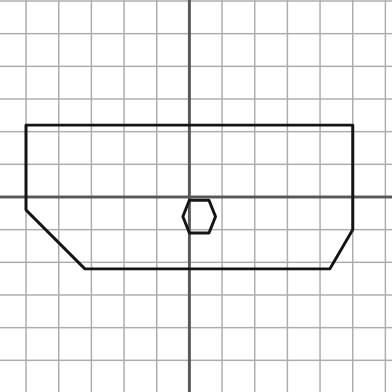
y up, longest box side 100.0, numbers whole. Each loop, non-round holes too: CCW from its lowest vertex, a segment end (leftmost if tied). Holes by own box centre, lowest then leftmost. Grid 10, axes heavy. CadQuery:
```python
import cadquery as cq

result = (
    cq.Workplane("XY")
    .moveTo(-32.0, -22.0)
    .lineTo(43.0, -22.0)
    .lineTo(50.0, -10.0)
    .lineTo(50.0, 22.0)
    .lineTo(-50.0, 22.0)
    .lineTo(-50.0, -4.0)
    .close()
    .moveTo(0.0, -11.0)
    .lineTo(6.0, -11.0)
    .lineTo(8.0, -6.0)
    .lineTo(6.0, -1.0)
    .lineTo(0.0, -1.0)
    .lineTo(-2.0, -6.0)
    .close()
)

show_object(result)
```